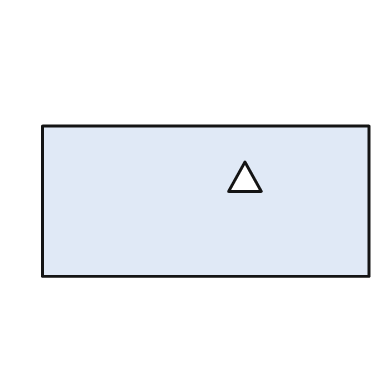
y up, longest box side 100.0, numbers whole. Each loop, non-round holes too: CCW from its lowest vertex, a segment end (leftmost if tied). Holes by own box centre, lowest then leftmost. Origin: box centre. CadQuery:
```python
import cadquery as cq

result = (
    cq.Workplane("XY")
    .moveTo(-50.0, -23.0)
    .lineTo(50.0, -23.0)
    .lineTo(50.0, 23.0)
    .lineTo(-50.0, 23.0)
    .close()
    .moveTo(7.0, 3.0)
    .lineTo(17.0, 3.0)
    .lineTo(12.0, 12.0)
    .close()
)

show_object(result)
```